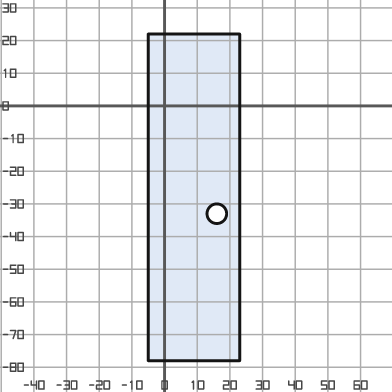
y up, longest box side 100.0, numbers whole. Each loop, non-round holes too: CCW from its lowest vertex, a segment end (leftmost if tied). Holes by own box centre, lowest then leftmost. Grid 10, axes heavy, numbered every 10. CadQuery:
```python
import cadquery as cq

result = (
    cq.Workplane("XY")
    .moveTo(-5.0, -78.0)
    .lineTo(23.0, -78.0)
    .lineTo(23.0, 22.0)
    .lineTo(-5.0, 22.0)
    .close()
    .moveTo(16.0, -33.0)
    .circle(3.0)
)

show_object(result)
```